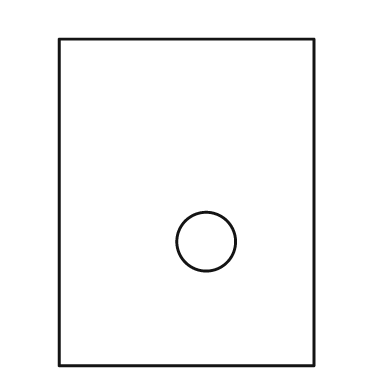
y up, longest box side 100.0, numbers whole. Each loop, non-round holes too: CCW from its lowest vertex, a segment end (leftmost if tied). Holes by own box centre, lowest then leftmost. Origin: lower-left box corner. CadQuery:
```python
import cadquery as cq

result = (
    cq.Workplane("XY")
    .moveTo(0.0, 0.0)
    .lineTo(78.0, 0.0)
    .lineTo(78.0, 100.0)
    .lineTo(0.0, 100.0)
    .close()
    .moveTo(45.0, 38.0)
    .circle(9.0)
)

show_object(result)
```